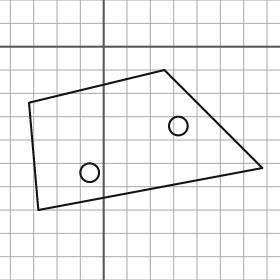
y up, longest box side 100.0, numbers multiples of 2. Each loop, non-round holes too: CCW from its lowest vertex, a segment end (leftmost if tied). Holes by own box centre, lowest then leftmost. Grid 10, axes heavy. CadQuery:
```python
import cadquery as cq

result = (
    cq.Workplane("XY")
    .moveTo(-28.0, -70.0)
    .lineTo(68.0, -52.0)
    .lineTo(26.0, -10.0)
    .lineTo(-32.0, -24.0)
    .close()
    .moveTo(-6.0, -54.0)
    .circle(4.0)
    .moveTo(32.0, -34.0)
    .circle(4.0)
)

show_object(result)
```